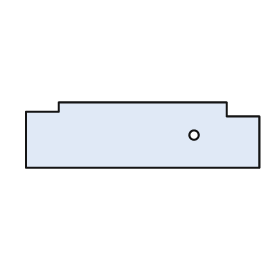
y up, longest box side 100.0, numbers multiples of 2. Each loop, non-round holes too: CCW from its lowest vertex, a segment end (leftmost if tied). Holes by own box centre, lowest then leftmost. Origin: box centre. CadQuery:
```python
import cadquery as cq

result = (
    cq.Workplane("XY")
    .moveTo(-50.0, -14.0)
    .lineTo(50.0, -14.0)
    .lineTo(50.0, 8.0)
    .lineTo(36.0, 8.0)
    .lineTo(36.0, 14.0)
    .lineTo(-36.0, 14.0)
    .lineTo(-36.0, 10.0)
    .lineTo(-50.0, 10.0)
    .close()
    .moveTo(22.0, 0.0)
    .circle(2.0)
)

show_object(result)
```